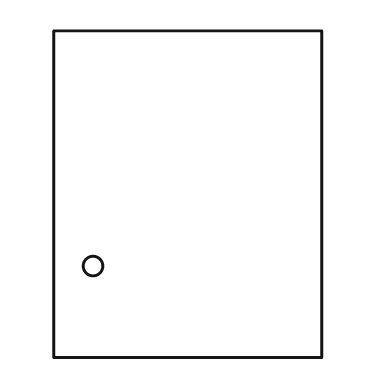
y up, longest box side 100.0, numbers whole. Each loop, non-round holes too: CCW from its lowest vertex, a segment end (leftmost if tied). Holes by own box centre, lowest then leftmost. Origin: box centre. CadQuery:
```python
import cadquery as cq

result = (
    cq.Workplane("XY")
    .moveTo(-41.0, -50.0)
    .lineTo(41.0, -50.0)
    .lineTo(41.0, 50.0)
    .lineTo(-41.0, 50.0)
    .close()
    .moveTo(-29.0, -22.0)
    .circle(3.0)
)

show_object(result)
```